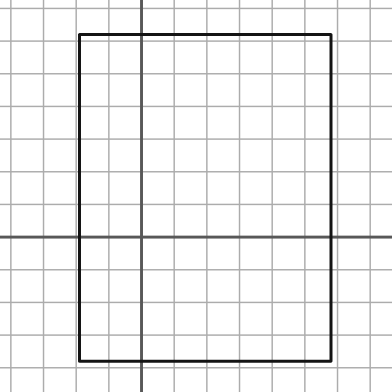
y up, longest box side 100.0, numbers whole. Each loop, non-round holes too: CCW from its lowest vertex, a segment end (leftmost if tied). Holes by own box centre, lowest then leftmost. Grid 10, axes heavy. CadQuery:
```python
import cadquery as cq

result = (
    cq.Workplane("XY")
    .moveTo(-19.0, -38.0)
    .lineTo(58.0, -38.0)
    .lineTo(58.0, 62.0)
    .lineTo(-19.0, 62.0)
    .close()
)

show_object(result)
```